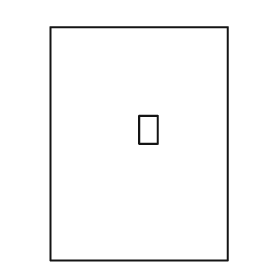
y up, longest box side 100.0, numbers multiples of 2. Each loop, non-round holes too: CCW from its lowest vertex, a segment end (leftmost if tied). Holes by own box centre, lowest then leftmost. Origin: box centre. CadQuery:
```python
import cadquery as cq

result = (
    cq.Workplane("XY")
    .moveTo(-38.0, -50.0)
    .lineTo(38.0, -50.0)
    .lineTo(38.0, 50.0)
    .lineTo(-38.0, 50.0)
    .close()
    .moveTo(0.0, 0.0)
    .lineTo(8.0, 0.0)
    .lineTo(8.0, 12.0)
    .lineTo(0.0, 12.0)
    .close()
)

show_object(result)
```